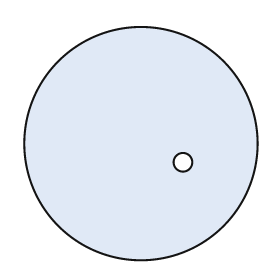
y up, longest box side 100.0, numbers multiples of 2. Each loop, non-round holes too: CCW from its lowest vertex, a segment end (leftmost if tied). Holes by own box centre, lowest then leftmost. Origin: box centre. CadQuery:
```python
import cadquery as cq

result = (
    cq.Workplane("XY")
    .moveTo(0.0, 0.0)
    .circle(50.0)
    .moveTo(18.0, -8.0)
    .circle(4.0)
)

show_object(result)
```